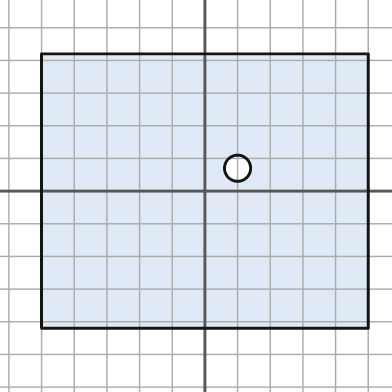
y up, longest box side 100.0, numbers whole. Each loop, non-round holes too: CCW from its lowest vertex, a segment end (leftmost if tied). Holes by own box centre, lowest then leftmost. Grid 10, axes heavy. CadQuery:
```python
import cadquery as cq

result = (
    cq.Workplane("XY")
    .moveTo(-50.0, -42.0)
    .lineTo(50.0, -42.0)
    .lineTo(50.0, 42.0)
    .lineTo(-50.0, 42.0)
    .close()
    .moveTo(10.0, 7.0)
    .circle(4.0)
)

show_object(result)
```